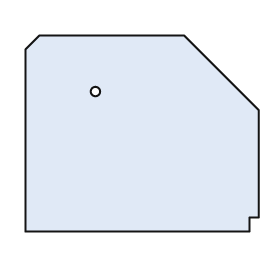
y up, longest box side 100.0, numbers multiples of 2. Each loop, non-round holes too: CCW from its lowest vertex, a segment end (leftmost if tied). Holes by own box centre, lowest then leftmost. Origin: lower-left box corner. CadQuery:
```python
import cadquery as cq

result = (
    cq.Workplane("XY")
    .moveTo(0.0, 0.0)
    .lineTo(96.0, 0.0)
    .lineTo(96.0, 6.0)
    .lineTo(100.0, 6.0)
    .lineTo(100.0, 52.0)
    .lineTo(68.0, 84.0)
    .lineTo(6.0, 84.0)
    .lineTo(0.0, 78.0)
    .close()
    .moveTo(30.0, 60.0)
    .circle(2.0)
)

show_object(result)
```